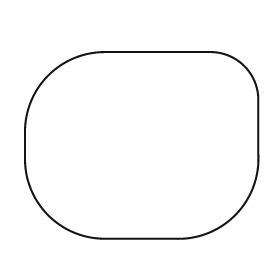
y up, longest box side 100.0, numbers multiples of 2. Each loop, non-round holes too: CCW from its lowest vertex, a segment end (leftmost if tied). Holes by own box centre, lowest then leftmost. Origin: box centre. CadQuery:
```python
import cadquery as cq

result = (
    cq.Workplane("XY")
    .moveTo(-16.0, -40.0)
    .lineTo(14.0, -40.0)
    .threePointArc((40.0, -30.0), (50.0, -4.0))
    .lineTo(50.0, 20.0)
    .threePointArc((44.0, 34.0), (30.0, 40.0))
    .lineTo(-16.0, 40.0)
    .threePointArc((-40.0, 30.0), (-50.0, 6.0))
    .lineTo(-50.0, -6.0)
    .threePointArc((-40.0, -30.0), (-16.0, -40.0))
    .close()
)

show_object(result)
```